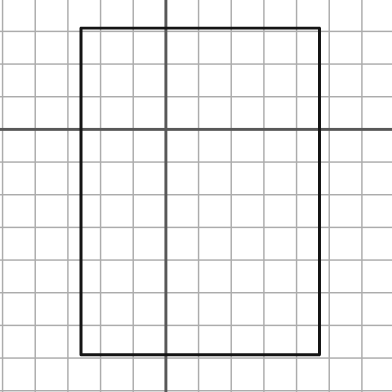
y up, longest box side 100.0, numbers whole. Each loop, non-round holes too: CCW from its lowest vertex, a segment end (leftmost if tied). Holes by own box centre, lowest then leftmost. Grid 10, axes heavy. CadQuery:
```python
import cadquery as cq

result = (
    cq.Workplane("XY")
    .moveTo(-26.0, -69.0)
    .lineTo(47.0, -69.0)
    .lineTo(47.0, 31.0)
    .lineTo(-26.0, 31.0)
    .close()
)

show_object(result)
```